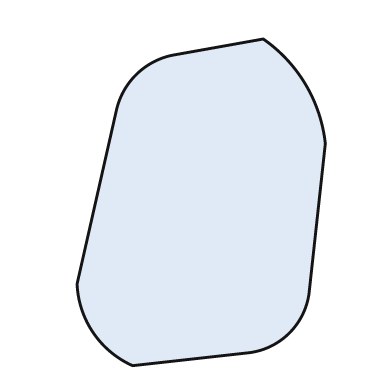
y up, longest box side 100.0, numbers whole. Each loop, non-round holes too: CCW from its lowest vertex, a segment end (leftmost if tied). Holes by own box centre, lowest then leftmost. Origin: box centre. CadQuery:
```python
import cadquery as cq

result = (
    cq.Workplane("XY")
    .moveTo(-21.0, -50.0)
    .lineTo(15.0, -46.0)
    .threePointArc((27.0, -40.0), (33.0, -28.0))
    .lineTo(38.0, 18.0)
    .threePointArc((32.0, 36.0), (19.0, 50.0))
    .lineTo(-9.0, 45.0)
    .threePointArc((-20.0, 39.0), (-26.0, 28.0))
    .lineTo(-38.0, -25.0)
    .threePointArc((-33.0, -40.0), (-21.0, -50.0))
    .close()
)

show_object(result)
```